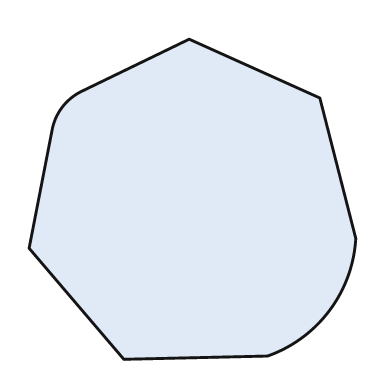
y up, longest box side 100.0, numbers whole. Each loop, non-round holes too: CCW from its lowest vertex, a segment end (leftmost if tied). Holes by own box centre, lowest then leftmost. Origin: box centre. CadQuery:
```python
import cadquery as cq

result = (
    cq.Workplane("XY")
    .moveTo(-21.0, -49.0)
    .lineTo(23.0, -48.0)
    .threePointArc((42.0, -34.0), (50.0, -12.0))
    .lineTo(39.0, 31.0)
    .lineTo(-1.0, 49.0)
    .lineTo(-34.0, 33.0)
    .threePointArc((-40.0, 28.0), (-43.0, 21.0))
    .lineTo(-50.0, -15.0)
    .close()
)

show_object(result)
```